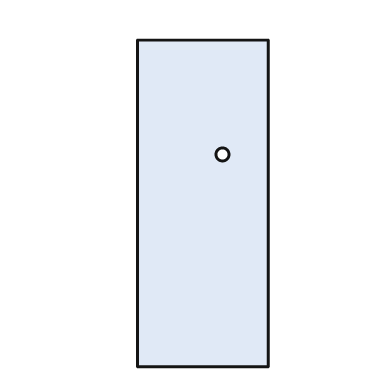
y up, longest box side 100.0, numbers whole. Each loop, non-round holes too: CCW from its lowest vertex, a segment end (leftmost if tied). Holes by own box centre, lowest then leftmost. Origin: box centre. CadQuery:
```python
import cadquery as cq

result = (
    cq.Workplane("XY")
    .moveTo(-20.0, -50.0)
    .lineTo(20.0, -50.0)
    .lineTo(20.0, 50.0)
    .lineTo(-20.0, 50.0)
    .close()
    .moveTo(6.0, 15.0)
    .circle(2.0)
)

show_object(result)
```